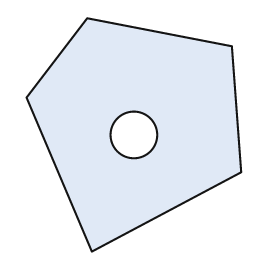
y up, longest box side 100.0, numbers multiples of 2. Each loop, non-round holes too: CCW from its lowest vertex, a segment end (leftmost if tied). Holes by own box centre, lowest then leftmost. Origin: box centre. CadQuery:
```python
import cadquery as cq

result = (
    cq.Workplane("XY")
    .moveTo(-18.0, -50.0)
    .lineTo(46.0, -16.0)
    .lineTo(42.0, 38.0)
    .lineTo(-20.0, 50.0)
    .lineTo(-46.0, 16.0)
    .close()
    .moveTo(0.0, 0.0)
    .circle(10.0)
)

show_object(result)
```